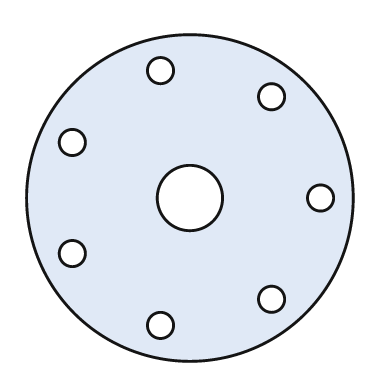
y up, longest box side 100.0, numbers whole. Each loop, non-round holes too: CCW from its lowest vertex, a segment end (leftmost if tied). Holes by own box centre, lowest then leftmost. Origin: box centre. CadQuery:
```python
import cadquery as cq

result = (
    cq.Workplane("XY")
    .moveTo(0.0, 0.0)
    .circle(50.0)
    .moveTo(-9.0, -39.0)
    .circle(4.0)
    .moveTo(25.0, -31.0)
    .circle(4.0)
    .moveTo(-36.0, -17.0)
    .circle(4.0)
    .moveTo(0.0, 0.0)
    .circle(10.0)
    .moveTo(40.0, 0.0)
    .circle(4.0)
    .moveTo(-36.0, 17.0)
    .circle(4.0)
    .moveTo(25.0, 31.0)
    .circle(4.0)
    .moveTo(-9.0, 39.0)
    .circle(4.0)
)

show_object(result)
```